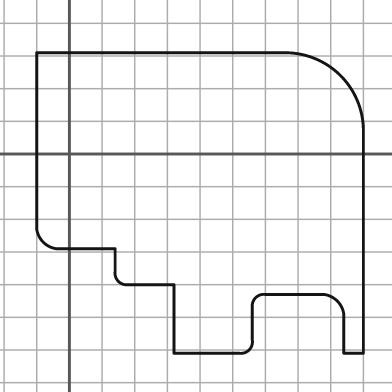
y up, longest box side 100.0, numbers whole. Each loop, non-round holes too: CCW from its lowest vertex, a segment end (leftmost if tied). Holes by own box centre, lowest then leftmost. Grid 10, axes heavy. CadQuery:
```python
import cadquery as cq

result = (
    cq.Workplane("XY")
    .moveTo(32.0, -61.0)
    .lineTo(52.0, -61.0)
    .threePointArc((55.0, -60.0), (56.0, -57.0))
    .lineTo(56.0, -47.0)
    .threePointArc((57.0, -44.0), (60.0, -43.0))
    .lineTo(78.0, -43.0)
    .threePointArc((82.0, -45.0), (84.0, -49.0))
    .lineTo(84.0, -61.0)
    .lineTo(90.0, -61.0)
    .lineTo(90.0, 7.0)
    .threePointArc((83.0, 24.0), (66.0, 31.0))
    .lineTo(-10.0, 31.0)
    .lineTo(-10.0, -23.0)
    .threePointArc((-8.0, -27.0), (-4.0, -29.0))
    .lineTo(14.0, -29.0)
    .lineTo(14.0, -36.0)
    .threePointArc((15.0, -39.0), (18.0, -40.0))
    .lineTo(32.0, -40.0)
    .close()
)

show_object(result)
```